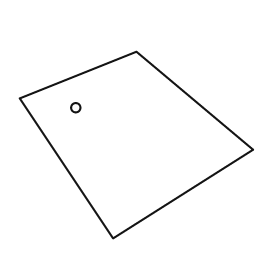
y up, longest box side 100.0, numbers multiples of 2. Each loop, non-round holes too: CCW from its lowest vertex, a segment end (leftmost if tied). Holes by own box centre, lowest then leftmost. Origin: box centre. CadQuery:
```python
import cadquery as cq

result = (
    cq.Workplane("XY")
    .moveTo(-10.0, -40.0)
    .lineTo(50.0, -2.0)
    .lineTo(0.0, 40.0)
    .lineTo(-50.0, 20.0)
    .close()
    .moveTo(-26.0, 16.0)
    .circle(2.0)
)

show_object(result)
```